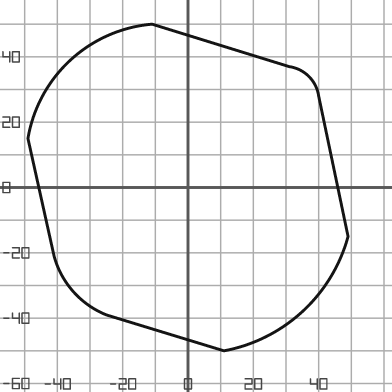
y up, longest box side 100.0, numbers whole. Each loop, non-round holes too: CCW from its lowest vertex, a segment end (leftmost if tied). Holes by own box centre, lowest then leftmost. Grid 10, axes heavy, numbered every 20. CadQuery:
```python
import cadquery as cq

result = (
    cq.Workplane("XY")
    .moveTo(11.0, -50.0)
    .threePointArc((35.0, -38.0), (49.0, -15.0))
    .lineTo(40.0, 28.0)
    .threePointArc((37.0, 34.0), (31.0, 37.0))
    .lineTo(-11.0, 50.0)
    .threePointArc((-36.0, 39.0), (-49.0, 15.0))
    .lineTo(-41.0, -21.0)
    .threePointArc((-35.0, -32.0), (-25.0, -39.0))
    .close()
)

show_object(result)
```